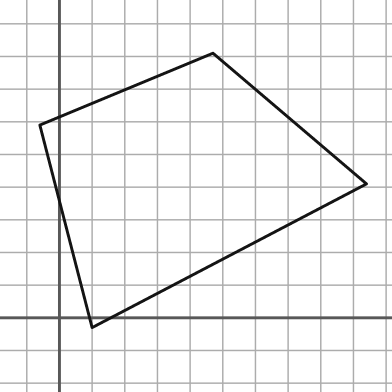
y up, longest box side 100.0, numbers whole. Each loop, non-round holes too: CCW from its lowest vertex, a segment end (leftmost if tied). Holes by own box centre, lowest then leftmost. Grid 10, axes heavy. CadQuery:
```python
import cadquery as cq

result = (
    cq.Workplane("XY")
    .moveTo(10.0, -3.0)
    .lineTo(94.0, 41.0)
    .lineTo(47.0, 81.0)
    .lineTo(-6.0, 59.0)
    .close()
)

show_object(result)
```